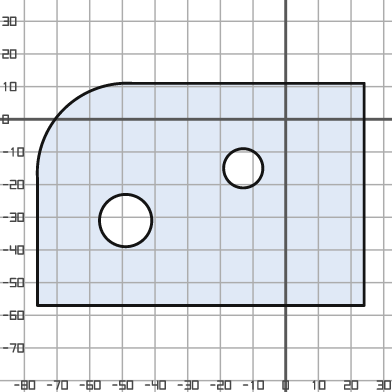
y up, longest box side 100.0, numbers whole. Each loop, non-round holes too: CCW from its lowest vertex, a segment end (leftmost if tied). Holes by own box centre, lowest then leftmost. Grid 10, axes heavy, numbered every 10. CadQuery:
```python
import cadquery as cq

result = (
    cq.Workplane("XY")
    .moveTo(-76.0, -57.0)
    .lineTo(24.0, -57.0)
    .lineTo(24.0, 11.0)
    .lineTo(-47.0, 11.0)
    .threePointArc((-68.0, 3.0), (-76.0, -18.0))
    .close()
    .moveTo(-49.0, -31.0)
    .circle(8.0)
    .moveTo(-13.0, -15.0)
    .circle(6.0)
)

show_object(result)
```